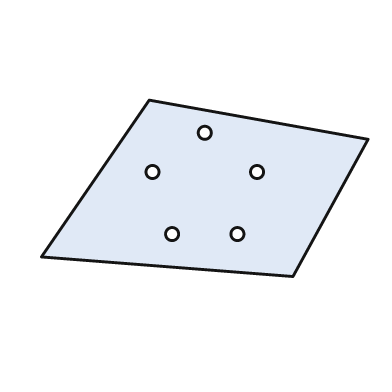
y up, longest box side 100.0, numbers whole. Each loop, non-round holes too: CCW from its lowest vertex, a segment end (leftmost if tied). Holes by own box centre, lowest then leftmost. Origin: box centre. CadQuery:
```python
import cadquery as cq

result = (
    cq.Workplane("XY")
    .moveTo(27.0, -27.0)
    .lineTo(50.0, 15.0)
    .lineTo(-17.0, 27.0)
    .lineTo(-50.0, -21.0)
    .close()
    .moveTo(-10.0, -14.0)
    .circle(2.0)
    .moveTo(10.0, -14.0)
    .circle(2.0)
    .moveTo(-16.0, 5.0)
    .circle(2.0)
    .moveTo(16.0, 5.0)
    .circle(2.0)
    .moveTo(0.0, 17.0)
    .circle(2.0)
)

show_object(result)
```